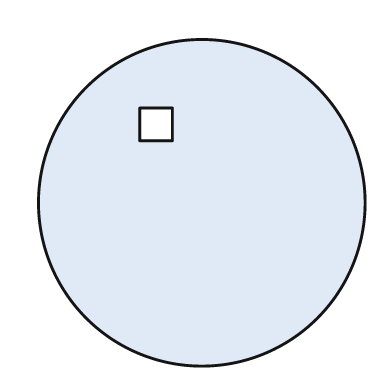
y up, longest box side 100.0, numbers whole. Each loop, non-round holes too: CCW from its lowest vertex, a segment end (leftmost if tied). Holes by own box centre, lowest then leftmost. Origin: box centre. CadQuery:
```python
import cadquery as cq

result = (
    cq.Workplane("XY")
    .moveTo(0.0, 0.0)
    .circle(50.0)
    .moveTo(-19.0, 19.0)
    .lineTo(-9.0, 19.0)
    .lineTo(-9.0, 29.0)
    .lineTo(-19.0, 29.0)
    .close()
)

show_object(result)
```